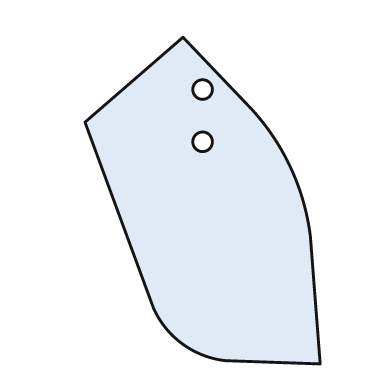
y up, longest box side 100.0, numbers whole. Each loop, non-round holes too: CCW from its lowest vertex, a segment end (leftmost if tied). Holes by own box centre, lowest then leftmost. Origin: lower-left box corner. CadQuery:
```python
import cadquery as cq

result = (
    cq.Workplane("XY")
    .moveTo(72.0, 0.0)
    .lineTo(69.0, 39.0)
    .threePointArc((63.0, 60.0), (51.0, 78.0))
    .lineTo(30.0, 100.0)
    .lineTo(0.0, 74.0)
    .lineTo(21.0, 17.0)
    .threePointArc((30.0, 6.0), (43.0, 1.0))
    .close()
    .moveTo(36.0, 68.0)
    .circle(3.0)
    .moveTo(36.0, 84.0)
    .circle(3.0)
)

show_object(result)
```